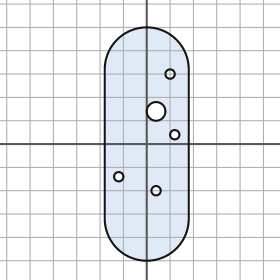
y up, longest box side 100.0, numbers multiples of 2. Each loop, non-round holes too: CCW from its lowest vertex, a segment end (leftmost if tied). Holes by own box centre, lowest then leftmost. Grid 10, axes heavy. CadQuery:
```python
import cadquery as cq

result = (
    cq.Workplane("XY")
    .moveTo(-18.0, -32.0)
    .threePointArc((0.0, -50.0), (18.0, -32.0))
    .lineTo(18.0, 32.0)
    .threePointArc((0.0, 50.0), (-18.0, 32.0))
    .close()
    .moveTo(4.0, -20.0)
    .circle(2.0)
    .moveTo(-12.0, -14.0)
    .circle(2.0)
    .moveTo(12.0, 4.0)
    .circle(2.0)
    .moveTo(4.0, 14.0)
    .circle(4.0)
    .moveTo(10.0, 30.0)
    .circle(2.0)
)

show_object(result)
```